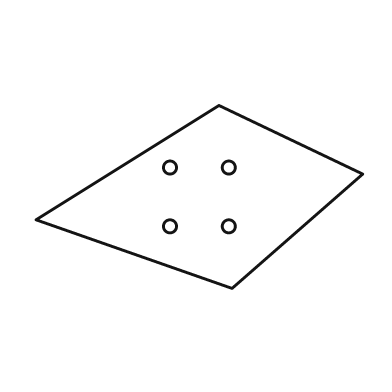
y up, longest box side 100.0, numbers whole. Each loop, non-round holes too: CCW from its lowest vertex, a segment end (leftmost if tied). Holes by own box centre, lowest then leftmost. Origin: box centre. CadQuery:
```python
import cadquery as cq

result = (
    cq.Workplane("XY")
    .moveTo(10.0, -28.0)
    .lineTo(50.0, 7.0)
    .lineTo(6.0, 28.0)
    .lineTo(-50.0, -7.0)
    .close()
    .moveTo(-9.0, -9.0)
    .circle(2.0)
    .moveTo(9.0, -9.0)
    .circle(2.0)
    .moveTo(-9.0, 9.0)
    .circle(2.0)
    .moveTo(9.0, 9.0)
    .circle(2.0)
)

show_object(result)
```